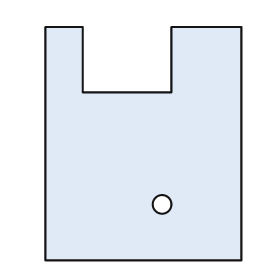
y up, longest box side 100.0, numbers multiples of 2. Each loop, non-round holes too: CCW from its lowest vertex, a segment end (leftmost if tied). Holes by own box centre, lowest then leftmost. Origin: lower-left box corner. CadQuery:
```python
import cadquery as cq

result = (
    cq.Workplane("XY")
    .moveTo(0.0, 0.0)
    .lineTo(84.0, 0.0)
    .lineTo(84.0, 100.0)
    .lineTo(54.0, 100.0)
    .lineTo(54.0, 72.0)
    .lineTo(16.0, 72.0)
    .lineTo(16.0, 100.0)
    .lineTo(0.0, 100.0)
    .close()
    .moveTo(50.0, 24.0)
    .circle(4.0)
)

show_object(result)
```